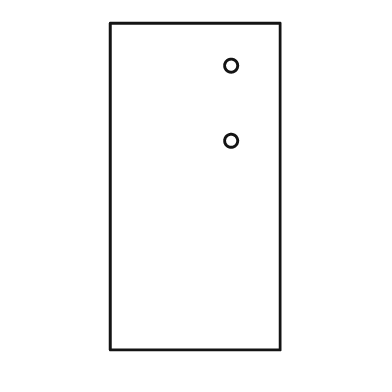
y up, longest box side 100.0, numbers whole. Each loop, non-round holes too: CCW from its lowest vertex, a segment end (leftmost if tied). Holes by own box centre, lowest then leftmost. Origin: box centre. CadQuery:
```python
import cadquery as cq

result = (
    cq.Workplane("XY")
    .moveTo(-26.0, -50.0)
    .lineTo(26.0, -50.0)
    .lineTo(26.0, 50.0)
    .lineTo(-26.0, 50.0)
    .close()
    .moveTo(11.0, 14.0)
    .circle(2.0)
    .moveTo(11.0, 37.0)
    .circle(2.0)
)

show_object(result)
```